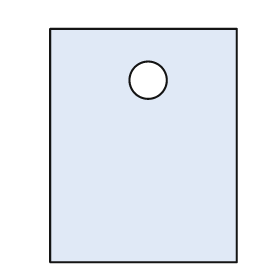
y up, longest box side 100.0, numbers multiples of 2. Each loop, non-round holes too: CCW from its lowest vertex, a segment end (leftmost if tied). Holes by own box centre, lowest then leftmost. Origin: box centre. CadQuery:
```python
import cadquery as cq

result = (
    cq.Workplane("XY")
    .moveTo(-40.0, -50.0)
    .lineTo(40.0, -50.0)
    .lineTo(40.0, 50.0)
    .lineTo(-40.0, 50.0)
    .close()
    .moveTo(2.0, 28.0)
    .circle(8.0)
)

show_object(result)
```